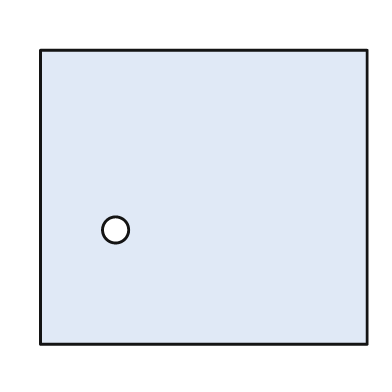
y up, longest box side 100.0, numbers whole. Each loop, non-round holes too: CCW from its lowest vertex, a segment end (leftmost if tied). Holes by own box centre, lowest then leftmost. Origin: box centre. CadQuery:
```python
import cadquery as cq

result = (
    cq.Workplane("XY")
    .moveTo(-50.0, -45.0)
    .lineTo(50.0, -45.0)
    .lineTo(50.0, 45.0)
    .lineTo(-50.0, 45.0)
    .close()
    .moveTo(-27.0, -10.0)
    .circle(4.0)
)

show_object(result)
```